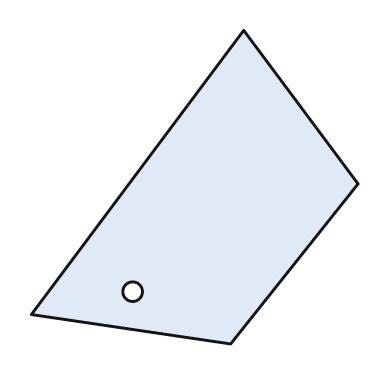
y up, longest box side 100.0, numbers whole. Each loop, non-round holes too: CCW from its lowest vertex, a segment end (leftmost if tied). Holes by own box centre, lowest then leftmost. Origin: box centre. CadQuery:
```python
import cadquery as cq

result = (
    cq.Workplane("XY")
    .moveTo(11.0, -48.0)
    .lineTo(50.0, 1.0)
    .lineTo(15.0, 48.0)
    .lineTo(-50.0, -39.0)
    .close()
    .moveTo(-19.0, -32.0)
    .circle(3.0)
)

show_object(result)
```